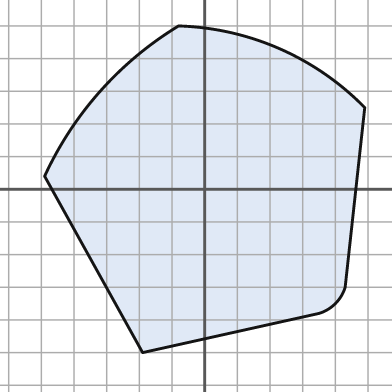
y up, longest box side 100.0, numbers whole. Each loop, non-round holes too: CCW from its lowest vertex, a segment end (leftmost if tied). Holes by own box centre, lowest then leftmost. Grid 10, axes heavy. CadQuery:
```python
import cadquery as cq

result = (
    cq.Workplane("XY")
    .moveTo(-19.0, -50.0)
    .lineTo(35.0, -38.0)
    .threePointArc((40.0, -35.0), (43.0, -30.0))
    .lineTo(49.0, 25.0)
    .threePointArc((23.0, 43.0), (-8.0, 50.0))
    .threePointArc((-32.0, 30.0), (-49.0, 4.0))
    .close()
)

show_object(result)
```